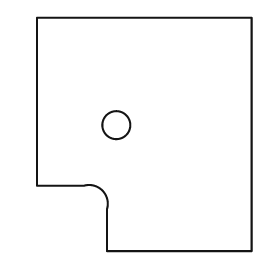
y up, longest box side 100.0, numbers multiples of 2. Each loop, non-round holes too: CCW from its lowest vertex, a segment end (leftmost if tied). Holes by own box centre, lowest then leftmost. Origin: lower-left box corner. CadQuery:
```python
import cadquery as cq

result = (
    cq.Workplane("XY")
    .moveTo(30.0, 0.0)
    .lineTo(92.0, 0.0)
    .lineTo(92.0, 100.0)
    .lineTo(0.0, 100.0)
    .lineTo(0.0, 28.0)
    .lineTo(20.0, 28.0)
    .threePointArc((28.0, 26.0), (30.0, 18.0))
    .close()
    .moveTo(34.0, 54.0)
    .circle(6.0)
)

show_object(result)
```